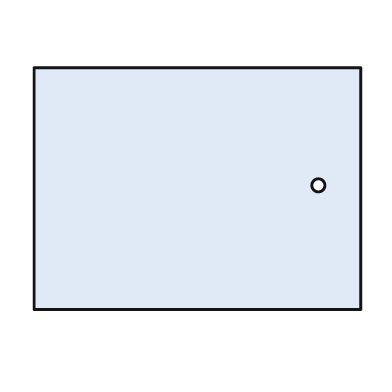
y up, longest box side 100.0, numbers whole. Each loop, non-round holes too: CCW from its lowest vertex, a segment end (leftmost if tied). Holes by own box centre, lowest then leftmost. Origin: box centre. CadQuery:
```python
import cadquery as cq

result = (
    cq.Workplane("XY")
    .moveTo(-50.0, -37.0)
    .lineTo(50.0, -37.0)
    .lineTo(50.0, 37.0)
    .lineTo(-50.0, 37.0)
    .close()
    .moveTo(37.0, 1.0)
    .circle(2.0)
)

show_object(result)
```